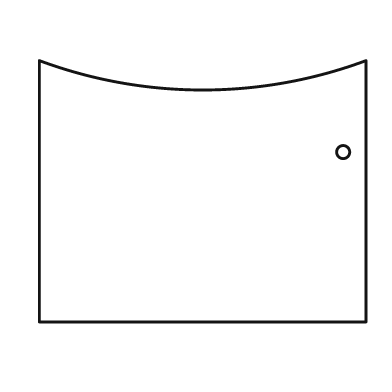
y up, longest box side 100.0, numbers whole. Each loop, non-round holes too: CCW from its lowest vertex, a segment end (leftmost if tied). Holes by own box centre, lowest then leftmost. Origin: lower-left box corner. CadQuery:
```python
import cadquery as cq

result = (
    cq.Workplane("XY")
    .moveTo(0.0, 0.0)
    .lineTo(100.0, 0.0)
    .lineTo(100.0, 80.0)
    .threePointArc((50.0, 71.0), (0.0, 80.0))
    .close()
    .moveTo(93.0, 52.0)
    .circle(2.0)
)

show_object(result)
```